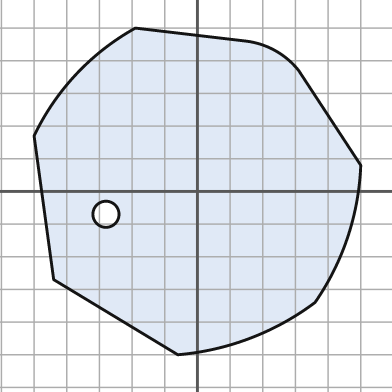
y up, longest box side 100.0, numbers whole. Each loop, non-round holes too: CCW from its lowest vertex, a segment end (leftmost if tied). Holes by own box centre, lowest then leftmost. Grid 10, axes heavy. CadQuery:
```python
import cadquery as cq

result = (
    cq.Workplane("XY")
    .moveTo(-6.0, -50.0)
    .threePointArc((16.0, -45.0), (36.0, -34.0))
    .threePointArc((46.0, -14.0), (50.0, 8.0))
    .lineTo(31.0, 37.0)
    .threePointArc((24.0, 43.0), (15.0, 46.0))
    .lineTo(-19.0, 50.0)
    .threePointArc((-37.0, 36.0), (-50.0, 17.0))
    .lineTo(-44.0, -27.0)
    .close()
    .moveTo(-28.0, -7.0)
    .circle(4.0)
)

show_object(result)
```